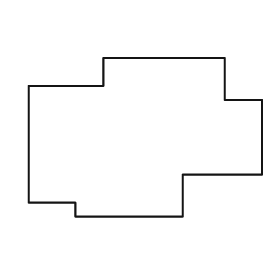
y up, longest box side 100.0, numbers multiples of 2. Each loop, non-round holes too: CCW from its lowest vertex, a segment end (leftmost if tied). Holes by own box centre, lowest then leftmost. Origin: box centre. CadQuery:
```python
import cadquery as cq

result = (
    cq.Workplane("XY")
    .moveTo(-30.0, -34.0)
    .lineTo(16.0, -34.0)
    .lineTo(16.0, -16.0)
    .lineTo(50.0, -16.0)
    .lineTo(50.0, 16.0)
    .lineTo(34.0, 16.0)
    .lineTo(34.0, 34.0)
    .lineTo(-18.0, 34.0)
    .lineTo(-18.0, 22.0)
    .lineTo(-50.0, 22.0)
    .lineTo(-50.0, -28.0)
    .lineTo(-30.0, -28.0)
    .close()
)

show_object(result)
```